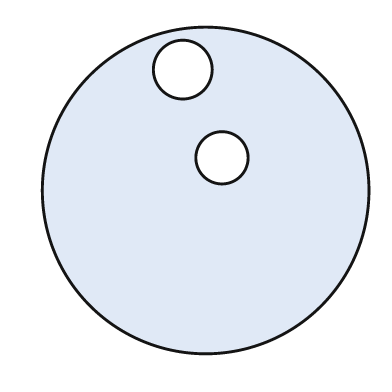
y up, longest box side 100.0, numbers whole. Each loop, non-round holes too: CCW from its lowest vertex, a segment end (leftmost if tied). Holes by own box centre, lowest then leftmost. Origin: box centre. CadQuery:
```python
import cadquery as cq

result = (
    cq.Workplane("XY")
    .moveTo(0.0, 0.0)
    .circle(50.0)
    .moveTo(5.0, 10.0)
    .circle(8.0)
    .moveTo(-7.0, 37.0)
    .circle(9.0)
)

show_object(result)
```